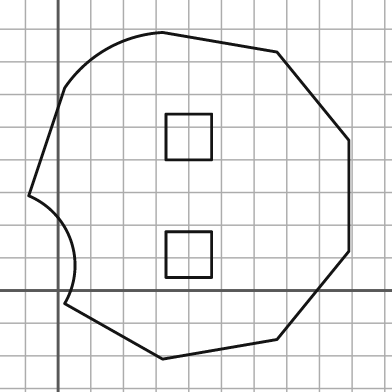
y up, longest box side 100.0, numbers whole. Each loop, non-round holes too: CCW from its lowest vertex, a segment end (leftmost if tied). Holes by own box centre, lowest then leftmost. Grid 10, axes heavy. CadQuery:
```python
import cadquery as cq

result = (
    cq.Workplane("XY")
    .moveTo(32.0, -21.0)
    .lineTo(67.0, -15.0)
    .lineTo(89.0, 12.0)
    .lineTo(89.0, 46.0)
    .lineTo(67.0, 73.0)
    .lineTo(32.0, 79.0)
    .threePointArc((15.0, 74.0), (2.0, 62.0))
    .lineTo(-9.0, 29.0)
    .threePointArc((4.0, 15.0), (2.0, -4.0))
    .close()
    .moveTo(33.0, 4.0)
    .lineTo(47.0, 4.0)
    .lineTo(47.0, 18.0)
    .lineTo(33.0, 18.0)
    .close()
    .moveTo(33.0, 40.0)
    .lineTo(47.0, 40.0)
    .lineTo(47.0, 54.0)
    .lineTo(33.0, 54.0)
    .close()
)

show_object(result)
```